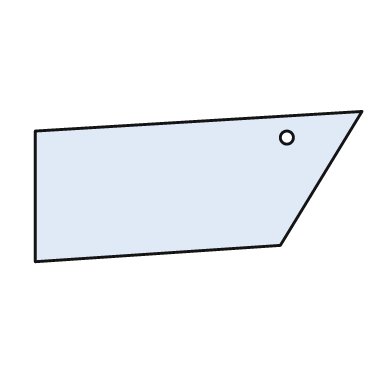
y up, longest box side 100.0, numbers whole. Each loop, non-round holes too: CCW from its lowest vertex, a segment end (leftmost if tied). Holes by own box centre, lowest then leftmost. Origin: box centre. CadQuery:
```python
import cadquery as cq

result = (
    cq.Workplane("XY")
    .moveTo(-50.0, -23.0)
    .lineTo(25.0, -18.0)
    .lineTo(50.0, 23.0)
    .lineTo(-50.0, 17.0)
    .close()
    .moveTo(27.0, 15.0)
    .circle(2.0)
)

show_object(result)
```